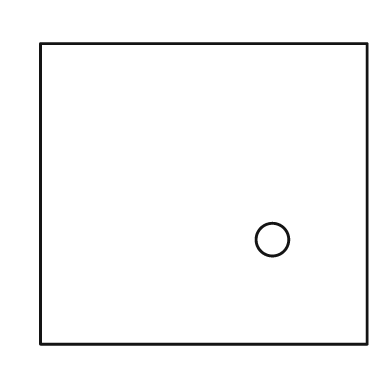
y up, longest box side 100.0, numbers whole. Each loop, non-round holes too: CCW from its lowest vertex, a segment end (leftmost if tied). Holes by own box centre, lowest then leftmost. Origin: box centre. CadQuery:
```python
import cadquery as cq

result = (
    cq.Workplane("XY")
    .moveTo(-50.0, -46.0)
    .lineTo(50.0, -46.0)
    .lineTo(50.0, 46.0)
    .lineTo(-50.0, 46.0)
    .close()
    .moveTo(21.0, -14.0)
    .circle(5.0)
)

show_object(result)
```